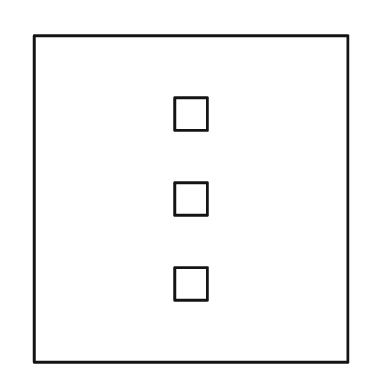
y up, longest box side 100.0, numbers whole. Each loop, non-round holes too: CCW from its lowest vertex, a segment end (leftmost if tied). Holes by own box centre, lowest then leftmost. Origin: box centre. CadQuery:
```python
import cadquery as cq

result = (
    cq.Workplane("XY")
    .moveTo(-48.0, -50.0)
    .lineTo(48.0, -50.0)
    .lineTo(48.0, 50.0)
    .lineTo(-48.0, 50.0)
    .close()
    .moveTo(-5.0, -31.0)
    .lineTo(5.0, -31.0)
    .lineTo(5.0, -21.0)
    .lineTo(-5.0, -21.0)
    .close()
    .moveTo(-5.0, -5.0)
    .lineTo(5.0, -5.0)
    .lineTo(5.0, 5.0)
    .lineTo(-5.0, 5.0)
    .close()
    .moveTo(-5.0, 21.0)
    .lineTo(5.0, 21.0)
    .lineTo(5.0, 31.0)
    .lineTo(-5.0, 31.0)
    .close()
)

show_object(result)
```